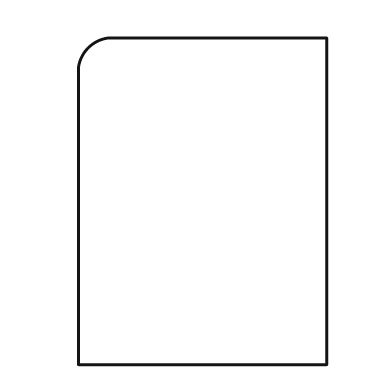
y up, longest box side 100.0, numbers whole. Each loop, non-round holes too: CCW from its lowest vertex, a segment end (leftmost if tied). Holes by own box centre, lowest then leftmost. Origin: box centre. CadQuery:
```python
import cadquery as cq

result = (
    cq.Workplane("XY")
    .moveTo(-38.0, -50.0)
    .lineTo(38.0, -50.0)
    .lineTo(38.0, 50.0)
    .lineTo(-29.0, 50.0)
    .threePointArc((-35.0, 47.0), (-38.0, 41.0))
    .close()
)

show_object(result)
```